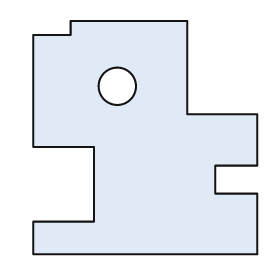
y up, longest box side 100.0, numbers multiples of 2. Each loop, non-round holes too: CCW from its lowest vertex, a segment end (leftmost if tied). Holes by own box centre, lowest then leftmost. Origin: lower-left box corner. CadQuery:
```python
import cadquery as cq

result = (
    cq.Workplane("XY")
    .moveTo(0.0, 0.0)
    .lineTo(96.0, 0.0)
    .lineTo(96.0, 26.0)
    .lineTo(78.0, 26.0)
    .lineTo(78.0, 38.0)
    .lineTo(96.0, 38.0)
    .lineTo(96.0, 60.0)
    .lineTo(66.0, 60.0)
    .lineTo(66.0, 100.0)
    .lineTo(16.0, 100.0)
    .lineTo(16.0, 94.0)
    .lineTo(0.0, 94.0)
    .lineTo(0.0, 46.0)
    .lineTo(26.0, 46.0)
    .lineTo(26.0, 14.0)
    .lineTo(0.0, 14.0)
    .close()
    .moveTo(36.0, 72.0)
    .circle(8.0)
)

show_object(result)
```